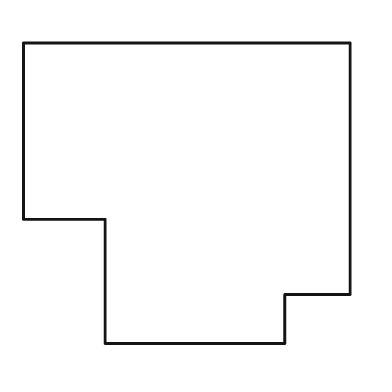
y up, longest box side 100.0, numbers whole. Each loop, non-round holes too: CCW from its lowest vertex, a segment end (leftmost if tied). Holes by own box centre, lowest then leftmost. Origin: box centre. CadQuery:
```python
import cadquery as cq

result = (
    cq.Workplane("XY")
    .moveTo(-25.0, -46.0)
    .lineTo(30.0, -46.0)
    .lineTo(30.0, -31.0)
    .lineTo(50.0, -31.0)
    .lineTo(50.0, 46.0)
    .lineTo(-50.0, 46.0)
    .lineTo(-50.0, -8.0)
    .lineTo(-25.0, -8.0)
    .close()
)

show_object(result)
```